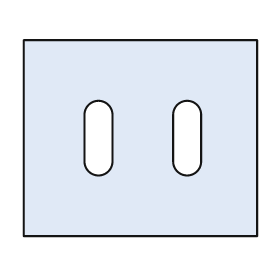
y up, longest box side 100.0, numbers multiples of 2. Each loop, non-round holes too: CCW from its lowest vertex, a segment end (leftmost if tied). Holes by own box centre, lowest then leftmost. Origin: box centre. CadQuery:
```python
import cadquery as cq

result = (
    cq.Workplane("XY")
    .moveTo(-50.0, -42.0)
    .lineTo(50.0, -42.0)
    .lineTo(50.0, 42.0)
    .lineTo(-50.0, 42.0)
    .close()
    .moveTo(-24.0, -10.0)
    .threePointArc((-18.0, -16.0), (-12.0, -10.0))
    .lineTo(-12.0, 10.0)
    .threePointArc((-18.0, 16.0), (-24.0, 10.0))
    .close()
    .moveTo(14.0, -10.0)
    .threePointArc((20.0, -16.0), (26.0, -10.0))
    .lineTo(26.0, 10.0)
    .threePointArc((20.0, 16.0), (14.0, 10.0))
    .close()
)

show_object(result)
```